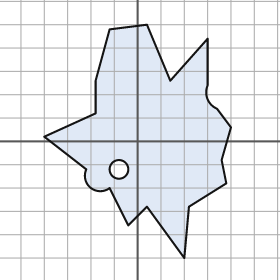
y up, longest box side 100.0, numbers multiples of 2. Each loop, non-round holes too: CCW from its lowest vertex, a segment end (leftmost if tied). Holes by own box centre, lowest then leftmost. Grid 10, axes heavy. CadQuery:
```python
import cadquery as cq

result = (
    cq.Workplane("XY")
    .moveTo(20.0, -50.0)
    .lineTo(22.0, -28.0)
    .lineTo(38.0, -18.0)
    .lineTo(36.0, -8.0)
    .lineTo(40.0, 6.0)
    .lineTo(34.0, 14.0)
    .threePointArc((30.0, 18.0), (30.0, 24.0))
    .lineTo(30.0, 44.0)
    .lineTo(14.0, 26.0)
    .lineTo(4.0, 50.0)
    .lineTo(-12.0, 48.0)
    .lineTo(-18.0, 26.0)
    .lineTo(-18.0, 12.0)
    .lineTo(-40.0, 2.0)
    .lineTo(-22.0, -12.0)
    .threePointArc((-20.0, -20.0), (-12.0, -20.0))
    .lineTo(-4.0, -36.0)
    .lineTo(4.0, -28.0)
    .close()
    .moveTo(-8.0, -12.0)
    .circle(4.0)
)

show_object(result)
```